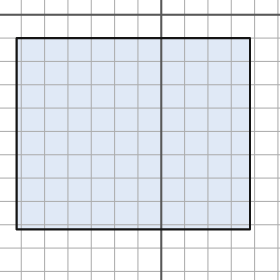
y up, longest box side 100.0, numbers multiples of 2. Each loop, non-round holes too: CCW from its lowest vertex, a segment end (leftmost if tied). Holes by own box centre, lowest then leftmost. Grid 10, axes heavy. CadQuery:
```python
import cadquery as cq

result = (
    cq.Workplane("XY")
    .moveTo(-62.0, -92.0)
    .lineTo(38.0, -92.0)
    .lineTo(38.0, -10.0)
    .lineTo(-62.0, -10.0)
    .close()
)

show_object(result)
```